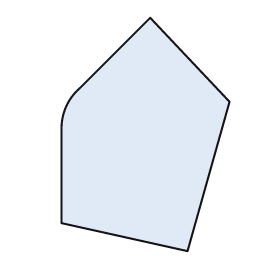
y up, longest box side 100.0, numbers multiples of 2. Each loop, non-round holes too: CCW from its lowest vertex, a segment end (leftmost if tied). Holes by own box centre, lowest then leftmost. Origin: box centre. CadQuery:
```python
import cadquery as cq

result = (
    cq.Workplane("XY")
    .moveTo(18.0, -50.0)
    .lineTo(36.0, 14.0)
    .lineTo(2.0, 50.0)
    .lineTo(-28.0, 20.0)
    .threePointArc((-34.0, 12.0), (-36.0, 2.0))
    .lineTo(-36.0, -38.0)
    .close()
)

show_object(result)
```